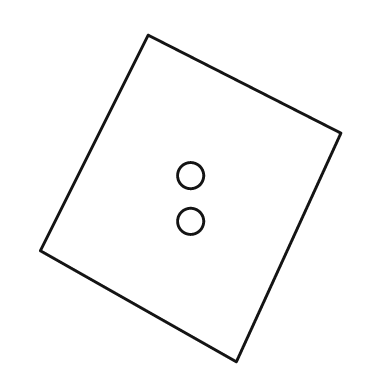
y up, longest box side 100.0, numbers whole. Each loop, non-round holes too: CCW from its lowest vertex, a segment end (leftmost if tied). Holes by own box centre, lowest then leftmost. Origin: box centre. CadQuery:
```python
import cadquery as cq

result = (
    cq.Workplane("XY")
    .moveTo(14.0, -50.0)
    .lineTo(46.0, 20.0)
    .lineTo(-13.0, 50.0)
    .lineTo(-46.0, -16.0)
    .close()
    .moveTo(0.0, -7.0)
    .circle(4.0)
    .moveTo(0.0, 7.0)
    .circle(4.0)
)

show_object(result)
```